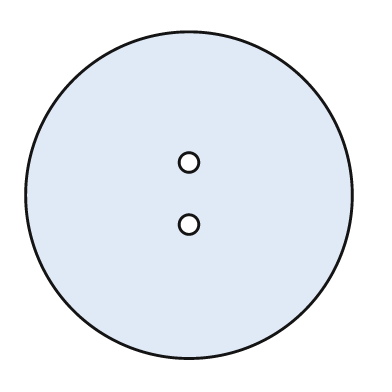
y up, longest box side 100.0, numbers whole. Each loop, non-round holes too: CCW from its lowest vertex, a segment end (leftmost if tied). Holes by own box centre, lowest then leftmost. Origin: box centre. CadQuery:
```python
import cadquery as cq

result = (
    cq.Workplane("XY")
    .moveTo(0.0, 0.0)
    .circle(50.0)
    .moveTo(0.0, -9.0)
    .circle(3.0)
    .moveTo(0.0, 10.0)
    .circle(3.0)
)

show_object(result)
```